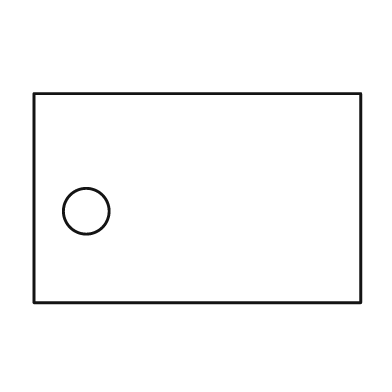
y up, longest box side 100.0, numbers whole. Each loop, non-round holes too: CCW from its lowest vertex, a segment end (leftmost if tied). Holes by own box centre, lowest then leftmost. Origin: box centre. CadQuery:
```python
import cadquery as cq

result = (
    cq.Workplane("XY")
    .moveTo(-50.0, -32.0)
    .lineTo(50.0, -32.0)
    .lineTo(50.0, 32.0)
    .lineTo(-50.0, 32.0)
    .close()
    .moveTo(-34.0, -4.0)
    .circle(7.0)
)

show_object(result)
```